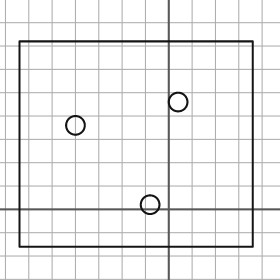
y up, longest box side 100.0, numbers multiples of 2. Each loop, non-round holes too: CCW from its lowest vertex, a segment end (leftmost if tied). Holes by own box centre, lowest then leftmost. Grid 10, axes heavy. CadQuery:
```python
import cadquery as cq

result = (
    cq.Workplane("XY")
    .moveTo(-64.0, -16.0)
    .lineTo(36.0, -16.0)
    .lineTo(36.0, 72.0)
    .lineTo(-64.0, 72.0)
    .close()
    .moveTo(-8.0, 2.0)
    .circle(4.0)
    .moveTo(-40.0, 36.0)
    .circle(4.0)
    .moveTo(4.0, 46.0)
    .circle(4.0)
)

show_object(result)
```